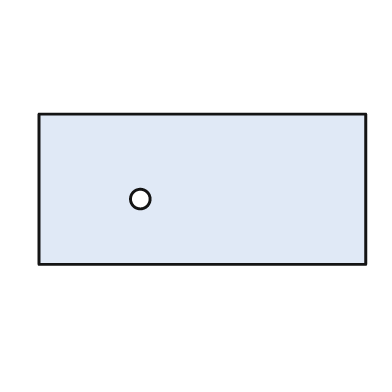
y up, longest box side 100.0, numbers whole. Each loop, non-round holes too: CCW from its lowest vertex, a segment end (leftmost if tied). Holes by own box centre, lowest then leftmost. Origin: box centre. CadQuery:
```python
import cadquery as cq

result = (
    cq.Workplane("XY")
    .moveTo(-50.0, -23.0)
    .lineTo(50.0, -23.0)
    .lineTo(50.0, 23.0)
    .lineTo(-50.0, 23.0)
    .close()
    .moveTo(-19.0, -3.0)
    .circle(3.0)
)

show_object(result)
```